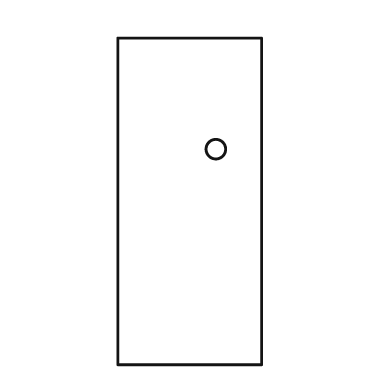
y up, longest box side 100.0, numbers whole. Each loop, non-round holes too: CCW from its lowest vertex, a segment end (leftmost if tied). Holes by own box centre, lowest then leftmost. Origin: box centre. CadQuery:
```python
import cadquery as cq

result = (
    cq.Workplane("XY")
    .moveTo(-22.0, -50.0)
    .lineTo(22.0, -50.0)
    .lineTo(22.0, 50.0)
    .lineTo(-22.0, 50.0)
    .close()
    .moveTo(8.0, 16.0)
    .circle(3.0)
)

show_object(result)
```